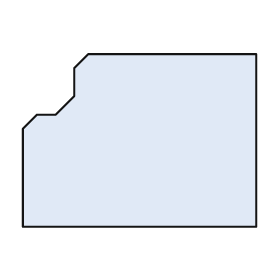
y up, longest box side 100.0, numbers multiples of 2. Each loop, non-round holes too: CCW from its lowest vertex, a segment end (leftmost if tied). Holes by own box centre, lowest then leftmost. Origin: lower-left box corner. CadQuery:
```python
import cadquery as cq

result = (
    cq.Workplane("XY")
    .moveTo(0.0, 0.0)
    .lineTo(100.0, 0.0)
    .lineTo(100.0, 74.0)
    .lineTo(28.0, 74.0)
    .lineTo(22.0, 68.0)
    .lineTo(22.0, 56.0)
    .lineTo(14.0, 48.0)
    .lineTo(6.0, 48.0)
    .lineTo(0.0, 42.0)
    .close()
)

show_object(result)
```